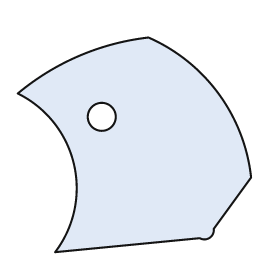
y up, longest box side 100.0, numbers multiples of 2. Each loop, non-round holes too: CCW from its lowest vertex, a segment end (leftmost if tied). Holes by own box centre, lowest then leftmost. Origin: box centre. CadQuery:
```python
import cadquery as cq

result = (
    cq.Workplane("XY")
    .moveTo(-34.0, -46.0)
    .lineTo(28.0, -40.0)
    .threePointArc((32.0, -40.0), (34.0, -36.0))
    .lineTo(50.0, -14.0)
    .threePointArc((36.0, 22.0), (6.0, 46.0))
    .threePointArc((-24.0, 38.0), (-50.0, 22.0))
    .threePointArc((-26.0, -8.0), (-34.0, -46.0))
    .close()
    .moveTo(-14.0, 12.0)
    .circle(6.0)
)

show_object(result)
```